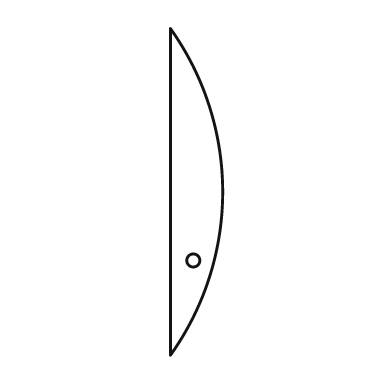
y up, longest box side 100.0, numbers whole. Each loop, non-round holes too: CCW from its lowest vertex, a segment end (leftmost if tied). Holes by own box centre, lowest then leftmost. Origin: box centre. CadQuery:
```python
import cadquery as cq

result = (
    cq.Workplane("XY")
    .moveTo(-8.0, -50.0)
    .threePointArc((8.0, 0.0), (-8.0, 50.0))
    .close()
    .moveTo(-1.0, -21.0)
    .circle(2.0)
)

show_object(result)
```